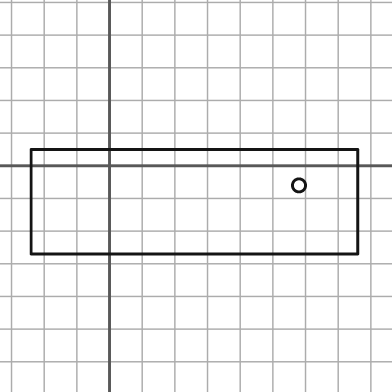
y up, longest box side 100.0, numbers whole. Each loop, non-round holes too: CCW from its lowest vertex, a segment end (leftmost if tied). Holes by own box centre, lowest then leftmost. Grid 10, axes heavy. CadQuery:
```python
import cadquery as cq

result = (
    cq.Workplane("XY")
    .moveTo(-24.0, -27.0)
    .lineTo(76.0, -27.0)
    .lineTo(76.0, 5.0)
    .lineTo(-24.0, 5.0)
    .close()
    .moveTo(58.0, -6.0)
    .circle(2.0)
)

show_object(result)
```